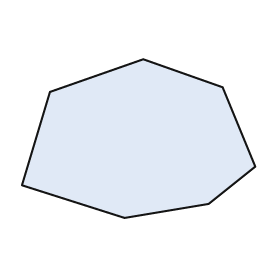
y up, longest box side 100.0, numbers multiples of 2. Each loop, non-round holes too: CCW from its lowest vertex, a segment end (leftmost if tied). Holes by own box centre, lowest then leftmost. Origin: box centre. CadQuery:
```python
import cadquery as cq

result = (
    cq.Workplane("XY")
    .moveTo(-6.0, -34.0)
    .lineTo(30.0, -28.0)
    .lineTo(50.0, -12.0)
    .lineTo(36.0, 22.0)
    .lineTo(2.0, 34.0)
    .lineTo(-38.0, 20.0)
    .lineTo(-50.0, -20.0)
    .close()
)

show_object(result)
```